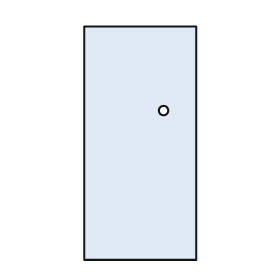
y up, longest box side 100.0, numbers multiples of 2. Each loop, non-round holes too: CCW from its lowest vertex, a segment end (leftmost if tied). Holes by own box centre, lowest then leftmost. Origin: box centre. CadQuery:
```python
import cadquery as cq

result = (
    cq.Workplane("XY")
    .moveTo(-24.0, -50.0)
    .lineTo(24.0, -50.0)
    .lineTo(24.0, 50.0)
    .lineTo(-24.0, 50.0)
    .close()
    .moveTo(10.0, 14.0)
    .circle(2.0)
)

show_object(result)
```